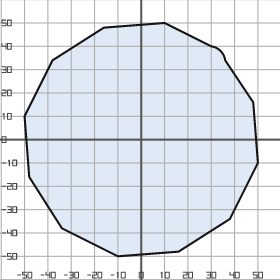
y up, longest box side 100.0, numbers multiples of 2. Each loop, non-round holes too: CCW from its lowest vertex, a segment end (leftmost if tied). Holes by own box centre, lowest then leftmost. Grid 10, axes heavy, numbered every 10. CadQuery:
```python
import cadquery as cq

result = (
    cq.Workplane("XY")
    .moveTo(-10.0, -50.0)
    .lineTo(16.0, -48.0)
    .lineTo(38.0, -34.0)
    .lineTo(50.0, -10.0)
    .lineTo(48.0, 16.0)
    .lineTo(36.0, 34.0)
    .threePointArc((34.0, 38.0), (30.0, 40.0))
    .lineTo(10.0, 50.0)
    .lineTo(-16.0, 48.0)
    .lineTo(-38.0, 34.0)
    .lineTo(-50.0, 10.0)
    .lineTo(-48.0, -16.0)
    .lineTo(-34.0, -38.0)
    .close()
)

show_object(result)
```